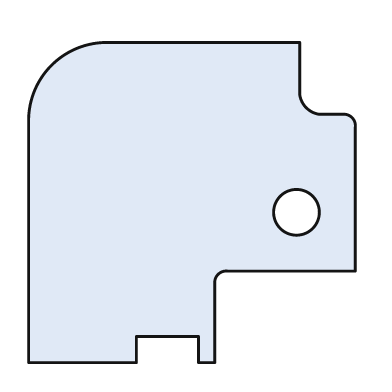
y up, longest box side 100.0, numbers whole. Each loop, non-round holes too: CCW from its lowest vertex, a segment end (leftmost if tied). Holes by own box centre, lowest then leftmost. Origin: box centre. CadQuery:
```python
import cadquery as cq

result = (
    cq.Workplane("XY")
    .moveTo(-50.0, -49.0)
    .lineTo(-17.0, -49.0)
    .lineTo(-17.0, -41.0)
    .lineTo(2.0, -41.0)
    .lineTo(2.0, -49.0)
    .lineTo(7.0, -49.0)
    .lineTo(7.0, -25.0)
    .threePointArc((8.0, -22.0), (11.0, -21.0))
    .lineTo(50.0, -21.0)
    .lineTo(50.0, 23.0)
    .threePointArc((49.0, 26.0), (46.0, 27.0))
    .lineTo(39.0, 27.0)
    .threePointArc((35.0, 29.0), (33.0, 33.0))
    .lineTo(33.0, 49.0)
    .lineTo(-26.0, 49.0)
    .threePointArc((-43.0, 42.0), (-50.0, 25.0))
    .close()
    .moveTo(32.0, -3.0)
    .circle(7.0)
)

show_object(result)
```